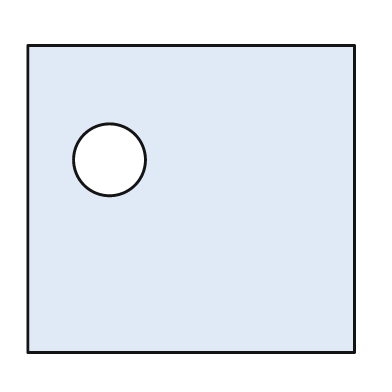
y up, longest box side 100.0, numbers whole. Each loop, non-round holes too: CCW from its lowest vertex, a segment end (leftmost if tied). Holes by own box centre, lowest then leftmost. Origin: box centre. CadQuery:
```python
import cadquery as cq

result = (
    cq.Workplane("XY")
    .moveTo(-50.0, -47.0)
    .lineTo(50.0, -47.0)
    .lineTo(50.0, 47.0)
    .lineTo(-50.0, 47.0)
    .close()
    .moveTo(-25.0, 12.0)
    .circle(11.0)
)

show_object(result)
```